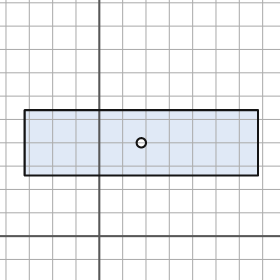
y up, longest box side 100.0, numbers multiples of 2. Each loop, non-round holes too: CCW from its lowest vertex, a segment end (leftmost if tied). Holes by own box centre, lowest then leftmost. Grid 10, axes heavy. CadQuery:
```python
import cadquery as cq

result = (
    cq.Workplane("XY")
    .moveTo(-32.0, 26.0)
    .lineTo(68.0, 26.0)
    .lineTo(68.0, 54.0)
    .lineTo(-32.0, 54.0)
    .close()
    .moveTo(18.0, 40.0)
    .circle(2.0)
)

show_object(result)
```